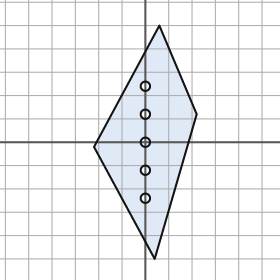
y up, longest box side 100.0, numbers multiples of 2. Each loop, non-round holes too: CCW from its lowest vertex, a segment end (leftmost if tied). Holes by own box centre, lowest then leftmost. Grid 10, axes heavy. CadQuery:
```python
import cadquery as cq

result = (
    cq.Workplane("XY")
    .moveTo(4.0, -50.0)
    .lineTo(22.0, 12.0)
    .lineTo(6.0, 50.0)
    .lineTo(-22.0, -2.0)
    .close()
    .moveTo(0.0, -24.0)
    .circle(2.0)
    .moveTo(0.0, -12.0)
    .circle(2.0)
    .moveTo(0.0, 0.0)
    .circle(2.0)
    .moveTo(0.0, 12.0)
    .circle(2.0)
    .moveTo(0.0, 24.0)
    .circle(2.0)
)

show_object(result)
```